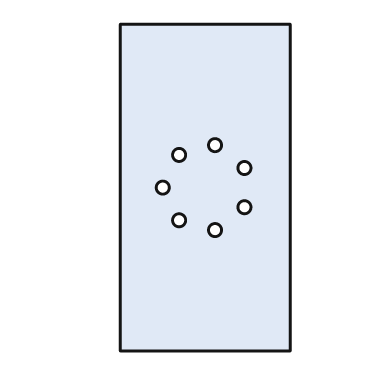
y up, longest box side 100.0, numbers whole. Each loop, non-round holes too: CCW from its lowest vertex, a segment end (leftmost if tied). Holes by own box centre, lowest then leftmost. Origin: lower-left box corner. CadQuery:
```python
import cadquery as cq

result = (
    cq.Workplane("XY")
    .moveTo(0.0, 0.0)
    .lineTo(52.0, 0.0)
    .lineTo(52.0, 100.0)
    .lineTo(0.0, 100.0)
    .close()
    .moveTo(29.0, 37.0)
    .circle(2.0)
    .moveTo(18.0, 40.0)
    .circle(2.0)
    .moveTo(38.0, 44.0)
    .circle(2.0)
    .moveTo(13.0, 50.0)
    .circle(2.0)
    .moveTo(38.0, 56.0)
    .circle(2.0)
    .moveTo(18.0, 60.0)
    .circle(2.0)
    .moveTo(29.0, 63.0)
    .circle(2.0)
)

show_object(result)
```